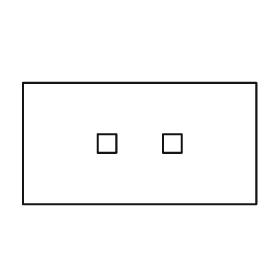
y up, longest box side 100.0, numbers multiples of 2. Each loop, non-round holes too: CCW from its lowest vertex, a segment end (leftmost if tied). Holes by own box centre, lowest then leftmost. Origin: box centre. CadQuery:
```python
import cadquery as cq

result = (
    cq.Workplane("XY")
    .moveTo(-50.0, -26.0)
    .lineTo(50.0, -26.0)
    .lineTo(50.0, 26.0)
    .lineTo(-50.0, 26.0)
    .close()
    .moveTo(-18.0, -4.0)
    .lineTo(-10.0, -4.0)
    .lineTo(-10.0, 4.0)
    .lineTo(-18.0, 4.0)
    .close()
    .moveTo(10.0, -4.0)
    .lineTo(18.0, -4.0)
    .lineTo(18.0, 4.0)
    .lineTo(10.0, 4.0)
    .close()
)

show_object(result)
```